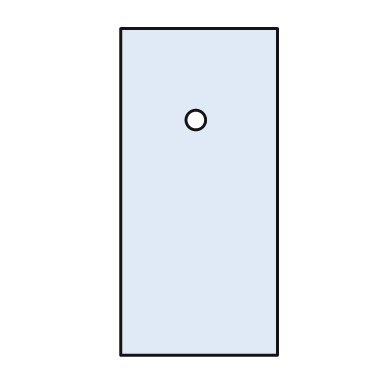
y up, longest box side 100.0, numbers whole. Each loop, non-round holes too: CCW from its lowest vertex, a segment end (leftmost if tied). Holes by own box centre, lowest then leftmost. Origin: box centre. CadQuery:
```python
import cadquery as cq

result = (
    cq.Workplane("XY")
    .moveTo(-24.0, -50.0)
    .lineTo(24.0, -50.0)
    .lineTo(24.0, 50.0)
    .lineTo(-24.0, 50.0)
    .close()
    .moveTo(-1.0, 22.0)
    .circle(3.0)
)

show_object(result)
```